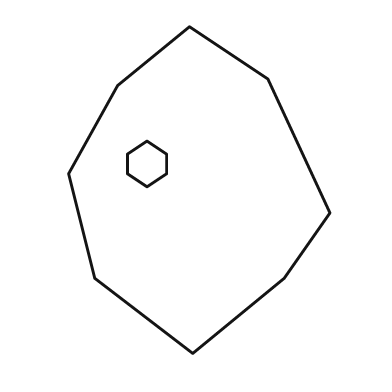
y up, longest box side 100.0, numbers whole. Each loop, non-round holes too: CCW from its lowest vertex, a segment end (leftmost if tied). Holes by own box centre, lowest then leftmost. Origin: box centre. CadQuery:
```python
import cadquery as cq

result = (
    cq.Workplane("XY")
    .moveTo(-2.0, -50.0)
    .lineTo(26.0, -27.0)
    .lineTo(40.0, -7.0)
    .lineTo(21.0, 34.0)
    .lineTo(-3.0, 50.0)
    .lineTo(-25.0, 32.0)
    .lineTo(-40.0, 5.0)
    .lineTo(-32.0, -27.0)
    .close()
    .moveTo(-16.0, 1.0)
    .lineTo(-10.0, 5.0)
    .lineTo(-10.0, 11.0)
    .lineTo(-16.0, 15.0)
    .lineTo(-22.0, 11.0)
    .lineTo(-22.0, 5.0)
    .close()
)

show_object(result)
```